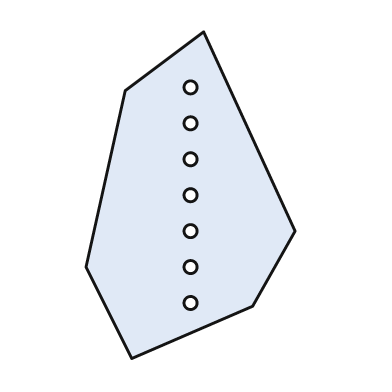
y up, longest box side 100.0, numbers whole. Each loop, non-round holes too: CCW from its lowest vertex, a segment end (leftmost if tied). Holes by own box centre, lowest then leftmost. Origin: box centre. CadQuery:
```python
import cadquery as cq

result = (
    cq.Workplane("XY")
    .moveTo(-18.0, -50.0)
    .lineTo(19.0, -34.0)
    .lineTo(32.0, -11.0)
    .lineTo(4.0, 50.0)
    .lineTo(-20.0, 32.0)
    .lineTo(-32.0, -22.0)
    .close()
    .moveTo(0.0, -33.0)
    .circle(2.0)
    .moveTo(0.0, -22.0)
    .circle(2.0)
    .moveTo(0.0, -11.0)
    .circle(2.0)
    .moveTo(0.0, 0.0)
    .circle(2.0)
    .moveTo(0.0, 11.0)
    .circle(2.0)
    .moveTo(0.0, 22.0)
    .circle(2.0)
    .moveTo(0.0, 33.0)
    .circle(2.0)
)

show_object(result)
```